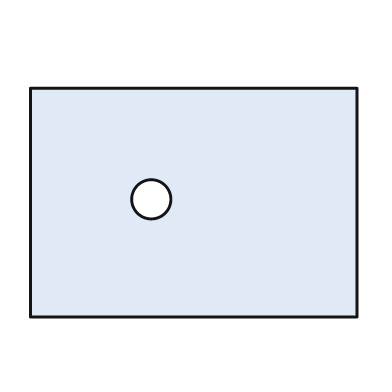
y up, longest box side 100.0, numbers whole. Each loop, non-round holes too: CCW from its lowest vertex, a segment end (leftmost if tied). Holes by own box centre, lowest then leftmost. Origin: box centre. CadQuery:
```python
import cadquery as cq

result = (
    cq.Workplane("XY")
    .moveTo(-50.0, -35.0)
    .lineTo(50.0, -35.0)
    .lineTo(50.0, 35.0)
    .lineTo(-50.0, 35.0)
    .close()
    .moveTo(-13.0, 1.0)
    .circle(6.0)
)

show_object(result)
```